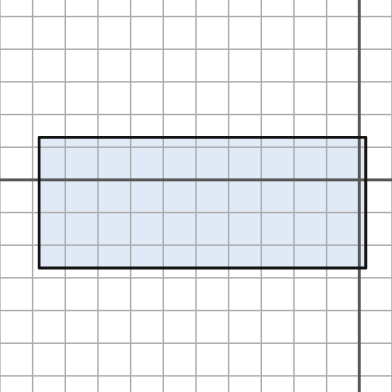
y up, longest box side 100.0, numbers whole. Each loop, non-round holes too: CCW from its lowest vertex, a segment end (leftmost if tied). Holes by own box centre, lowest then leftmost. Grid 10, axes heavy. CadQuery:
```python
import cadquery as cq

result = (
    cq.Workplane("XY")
    .moveTo(-98.0, -27.0)
    .lineTo(2.0, -27.0)
    .lineTo(2.0, 13.0)
    .lineTo(-98.0, 13.0)
    .close()
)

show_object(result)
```